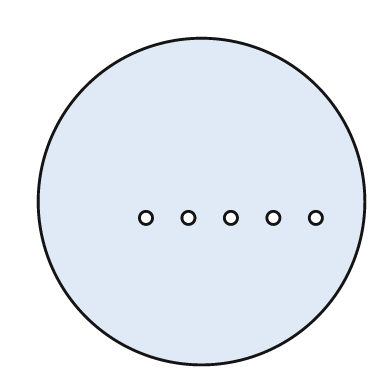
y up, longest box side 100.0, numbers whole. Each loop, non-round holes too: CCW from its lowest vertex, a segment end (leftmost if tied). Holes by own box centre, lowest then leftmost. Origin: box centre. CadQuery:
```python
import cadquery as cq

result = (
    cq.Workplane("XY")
    .moveTo(0.0, 0.0)
    .circle(50.0)
    .moveTo(-17.0, -5.0)
    .circle(2.0)
    .moveTo(-4.0, -5.0)
    .circle(2.0)
    .moveTo(9.0, -5.0)
    .circle(2.0)
    .moveTo(22.0, -5.0)
    .circle(2.0)
    .moveTo(35.0, -5.0)
    .circle(2.0)
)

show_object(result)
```